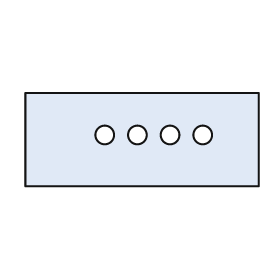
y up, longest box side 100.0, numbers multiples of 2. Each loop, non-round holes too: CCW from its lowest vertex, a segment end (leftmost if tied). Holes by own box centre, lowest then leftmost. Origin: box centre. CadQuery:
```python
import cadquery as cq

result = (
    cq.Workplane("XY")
    .moveTo(-50.0, -20.0)
    .lineTo(50.0, -20.0)
    .lineTo(50.0, 20.0)
    .lineTo(-50.0, 20.0)
    .close()
    .moveTo(-16.0, 2.0)
    .circle(4.0)
    .moveTo(-2.0, 2.0)
    .circle(4.0)
    .moveTo(12.0, 2.0)
    .circle(4.0)
    .moveTo(26.0, 2.0)
    .circle(4.0)
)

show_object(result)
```